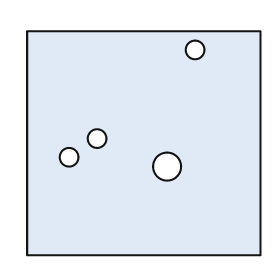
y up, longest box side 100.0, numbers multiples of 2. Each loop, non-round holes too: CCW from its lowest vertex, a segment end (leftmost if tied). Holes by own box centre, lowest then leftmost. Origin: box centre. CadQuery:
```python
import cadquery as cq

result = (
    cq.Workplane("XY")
    .moveTo(-50.0, -48.0)
    .lineTo(50.0, -48.0)
    .lineTo(50.0, 48.0)
    .lineTo(-50.0, 48.0)
    .close()
    .moveTo(10.0, -10.0)
    .circle(6.0)
    .moveTo(-32.0, -6.0)
    .circle(4.0)
    .moveTo(-20.0, 2.0)
    .circle(4.0)
    .moveTo(22.0, 40.0)
    .circle(4.0)
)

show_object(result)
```